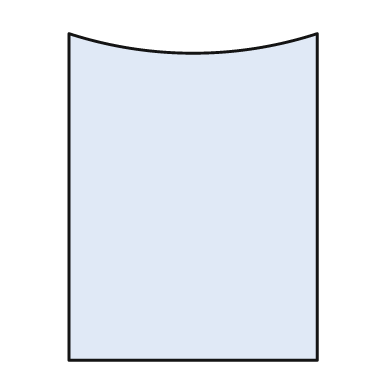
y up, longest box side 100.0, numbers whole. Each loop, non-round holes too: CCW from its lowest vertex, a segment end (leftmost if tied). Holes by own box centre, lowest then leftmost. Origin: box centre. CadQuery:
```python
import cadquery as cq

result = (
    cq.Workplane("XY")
    .moveTo(-38.0, -50.0)
    .lineTo(38.0, -50.0)
    .lineTo(38.0, 50.0)
    .threePointArc((0.0, 44.0), (-38.0, 50.0))
    .close()
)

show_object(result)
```